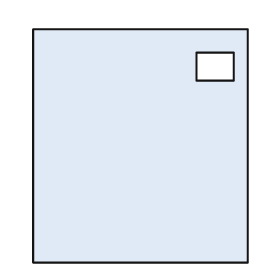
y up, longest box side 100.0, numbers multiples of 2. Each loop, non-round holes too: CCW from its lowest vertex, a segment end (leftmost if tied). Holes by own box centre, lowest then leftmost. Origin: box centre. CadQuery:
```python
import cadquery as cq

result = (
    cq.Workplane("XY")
    .moveTo(-46.0, -50.0)
    .lineTo(46.0, -50.0)
    .lineTo(46.0, 50.0)
    .lineTo(-46.0, 50.0)
    .close()
    .moveTo(24.0, 28.0)
    .lineTo(40.0, 28.0)
    .lineTo(40.0, 40.0)
    .lineTo(24.0, 40.0)
    .close()
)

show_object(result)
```